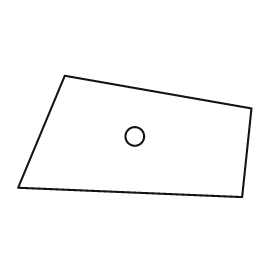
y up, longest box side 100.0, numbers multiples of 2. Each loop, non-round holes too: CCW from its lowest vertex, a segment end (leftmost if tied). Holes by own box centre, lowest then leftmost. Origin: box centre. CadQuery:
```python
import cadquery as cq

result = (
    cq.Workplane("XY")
    .moveTo(46.0, -26.0)
    .lineTo(50.0, 12.0)
    .lineTo(-30.0, 26.0)
    .lineTo(-50.0, -22.0)
    .close()
    .moveTo(0.0, 0.0)
    .circle(4.0)
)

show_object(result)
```